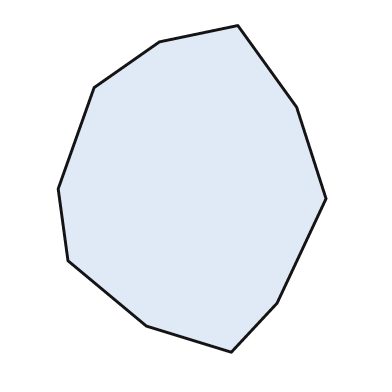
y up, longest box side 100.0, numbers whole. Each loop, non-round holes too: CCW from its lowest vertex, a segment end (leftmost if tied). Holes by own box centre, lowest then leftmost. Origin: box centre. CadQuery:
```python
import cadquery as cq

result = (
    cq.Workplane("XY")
    .moveTo(12.0, -50.0)
    .lineTo(26.0, -35.0)
    .lineTo(41.0, -3.0)
    .lineTo(32.0, 25.0)
    .lineTo(14.0, 50.0)
    .lineTo(-10.0, 45.0)
    .lineTo(-30.0, 31.0)
    .lineTo(-41.0, 0.0)
    .lineTo(-38.0, -22.0)
    .lineTo(-14.0, -42.0)
    .close()
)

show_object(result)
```